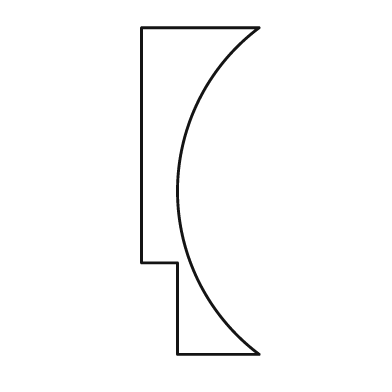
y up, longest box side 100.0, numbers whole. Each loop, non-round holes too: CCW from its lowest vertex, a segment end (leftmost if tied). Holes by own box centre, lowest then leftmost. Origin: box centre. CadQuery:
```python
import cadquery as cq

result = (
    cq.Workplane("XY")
    .moveTo(-7.0, -50.0)
    .lineTo(18.0, -50.0)
    .threePointArc((-7.0, 0.0), (18.0, 50.0))
    .lineTo(-18.0, 50.0)
    .lineTo(-18.0, -22.0)
    .lineTo(-7.0, -22.0)
    .close()
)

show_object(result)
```